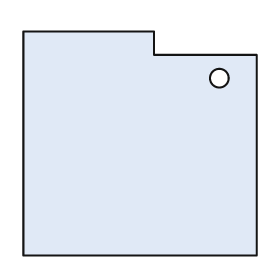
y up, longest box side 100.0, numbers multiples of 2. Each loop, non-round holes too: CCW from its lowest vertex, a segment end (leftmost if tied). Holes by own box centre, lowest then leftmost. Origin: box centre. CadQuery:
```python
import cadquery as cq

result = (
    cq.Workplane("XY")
    .moveTo(-50.0, -48.0)
    .lineTo(50.0, -48.0)
    .lineTo(50.0, 38.0)
    .lineTo(6.0, 38.0)
    .lineTo(6.0, 48.0)
    .lineTo(-50.0, 48.0)
    .close()
    .moveTo(34.0, 28.0)
    .circle(4.0)
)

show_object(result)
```